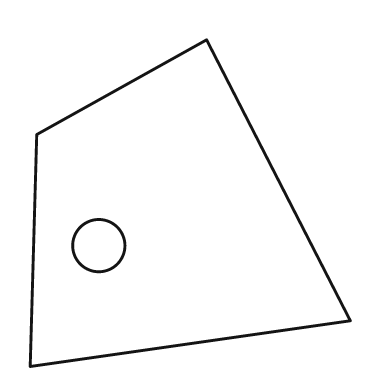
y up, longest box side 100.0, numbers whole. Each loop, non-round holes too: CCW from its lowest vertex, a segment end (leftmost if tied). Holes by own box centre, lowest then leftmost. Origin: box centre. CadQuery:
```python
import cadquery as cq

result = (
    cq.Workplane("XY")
    .moveTo(-49.0, -50.0)
    .lineTo(49.0, -36.0)
    .lineTo(5.0, 50.0)
    .lineTo(-47.0, 21.0)
    .close()
    .moveTo(-28.0, -13.0)
    .circle(8.0)
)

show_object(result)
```